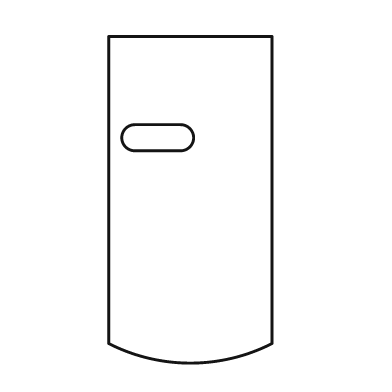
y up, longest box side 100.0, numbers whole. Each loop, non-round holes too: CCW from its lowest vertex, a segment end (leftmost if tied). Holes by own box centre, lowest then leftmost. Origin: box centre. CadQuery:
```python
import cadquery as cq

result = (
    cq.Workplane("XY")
    .moveTo(-25.0, -44.0)
    .threePointArc((0.0, -50.0), (25.0, -44.0))
    .lineTo(25.0, 50.0)
    .lineTo(-25.0, 50.0)
    .close()
    .moveTo(-17.0, 15.0)
    .lineTo(-3.0, 15.0)
    .threePointArc((1.0, 19.0), (-3.0, 23.0))
    .lineTo(-17.0, 23.0)
    .threePointArc((-21.0, 19.0), (-17.0, 15.0))
    .close()
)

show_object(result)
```